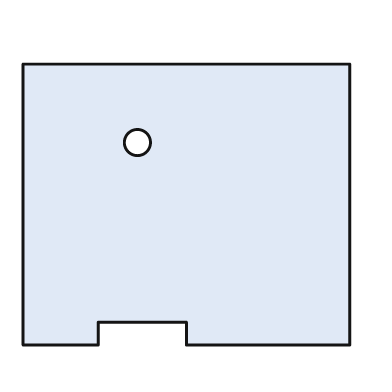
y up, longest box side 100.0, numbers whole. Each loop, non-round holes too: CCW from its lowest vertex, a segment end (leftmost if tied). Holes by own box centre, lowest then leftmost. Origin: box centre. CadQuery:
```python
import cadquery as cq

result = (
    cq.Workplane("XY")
    .moveTo(-50.0, -43.0)
    .lineTo(-27.0, -43.0)
    .lineTo(-27.0, -36.0)
    .lineTo(0.0, -36.0)
    .lineTo(0.0, -43.0)
    .lineTo(50.0, -43.0)
    .lineTo(50.0, 43.0)
    .lineTo(-50.0, 43.0)
    .close()
    .moveTo(-15.0, 19.0)
    .circle(4.0)
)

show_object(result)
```